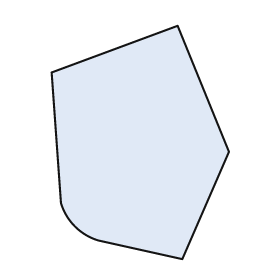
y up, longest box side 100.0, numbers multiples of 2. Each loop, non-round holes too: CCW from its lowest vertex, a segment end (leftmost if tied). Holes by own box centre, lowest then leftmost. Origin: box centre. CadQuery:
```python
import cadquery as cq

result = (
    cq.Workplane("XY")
    .moveTo(18.0, -50.0)
    .lineTo(38.0, -4.0)
    .lineTo(16.0, 50.0)
    .lineTo(-38.0, 30.0)
    .lineTo(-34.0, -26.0)
    .threePointArc((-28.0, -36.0), (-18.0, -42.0))
    .close()
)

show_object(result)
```